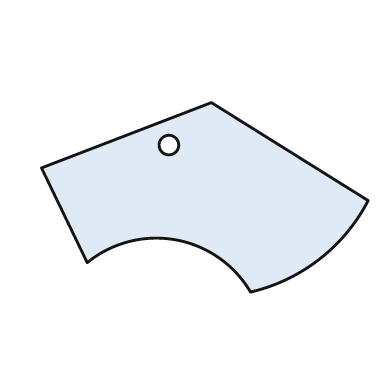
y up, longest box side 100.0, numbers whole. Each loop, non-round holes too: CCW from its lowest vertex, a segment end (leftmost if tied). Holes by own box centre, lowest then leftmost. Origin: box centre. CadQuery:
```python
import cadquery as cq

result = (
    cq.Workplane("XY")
    .moveTo(14.0, -29.0)
    .threePointArc((35.0, -19.0), (50.0, -1.0))
    .lineTo(2.0, 29.0)
    .lineTo(-50.0, 9.0)
    .lineTo(-36.0, -20.0)
    .threePointArc((-9.0, -13.0), (14.0, -29.0))
    .close()
    .moveTo(-11.0, 16.0)
    .circle(3.0)
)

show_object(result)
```